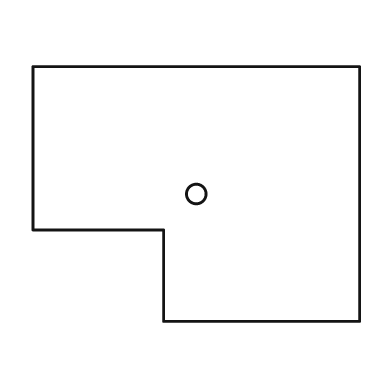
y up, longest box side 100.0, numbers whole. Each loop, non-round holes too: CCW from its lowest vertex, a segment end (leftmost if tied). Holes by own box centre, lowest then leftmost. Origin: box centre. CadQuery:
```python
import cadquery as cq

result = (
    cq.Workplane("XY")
    .moveTo(-10.0, -39.0)
    .lineTo(50.0, -39.0)
    .lineTo(50.0, 39.0)
    .lineTo(-50.0, 39.0)
    .lineTo(-50.0, -11.0)
    .lineTo(-10.0, -11.0)
    .close()
    .moveTo(0.0, 0.0)
    .circle(3.0)
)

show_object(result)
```